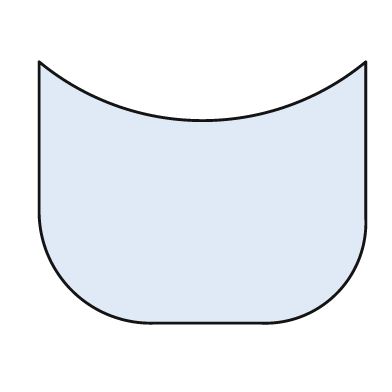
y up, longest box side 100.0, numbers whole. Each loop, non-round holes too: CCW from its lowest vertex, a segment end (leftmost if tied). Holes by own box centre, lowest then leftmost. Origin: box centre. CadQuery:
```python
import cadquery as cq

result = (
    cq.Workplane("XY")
    .moveTo(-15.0, -40.0)
    .lineTo(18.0, -40.0)
    .threePointArc((41.0, -31.0), (50.0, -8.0))
    .lineTo(50.0, 40.0)
    .threePointArc((0.0, 22.0), (-50.0, 40.0))
    .lineTo(-50.0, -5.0)
    .threePointArc((-40.0, -30.0), (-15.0, -40.0))
    .close()
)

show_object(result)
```